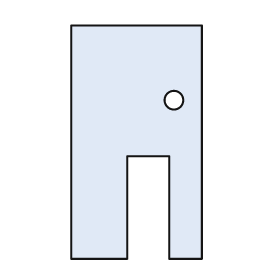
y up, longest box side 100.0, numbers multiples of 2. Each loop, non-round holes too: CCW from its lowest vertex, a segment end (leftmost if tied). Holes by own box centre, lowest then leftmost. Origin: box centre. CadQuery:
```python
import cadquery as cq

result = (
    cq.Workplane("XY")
    .moveTo(-28.0, -50.0)
    .lineTo(-4.0, -50.0)
    .lineTo(-4.0, -6.0)
    .lineTo(14.0, -6.0)
    .lineTo(14.0, -50.0)
    .lineTo(28.0, -50.0)
    .lineTo(28.0, 50.0)
    .lineTo(-28.0, 50.0)
    .close()
    .moveTo(16.0, 18.0)
    .circle(4.0)
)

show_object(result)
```